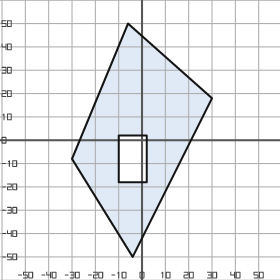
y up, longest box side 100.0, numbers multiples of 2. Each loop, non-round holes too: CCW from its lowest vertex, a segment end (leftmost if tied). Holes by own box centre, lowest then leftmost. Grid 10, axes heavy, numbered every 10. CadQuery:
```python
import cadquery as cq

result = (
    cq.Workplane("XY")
    .moveTo(-4.0, -50.0)
    .lineTo(30.0, 18.0)
    .lineTo(-6.0, 50.0)
    .lineTo(-30.0, -8.0)
    .close()
    .moveTo(-10.0, -18.0)
    .lineTo(2.0, -18.0)
    .lineTo(2.0, 2.0)
    .lineTo(-10.0, 2.0)
    .close()
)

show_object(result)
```